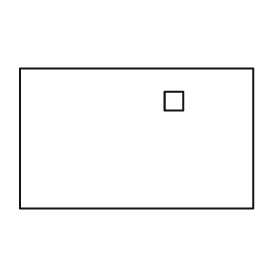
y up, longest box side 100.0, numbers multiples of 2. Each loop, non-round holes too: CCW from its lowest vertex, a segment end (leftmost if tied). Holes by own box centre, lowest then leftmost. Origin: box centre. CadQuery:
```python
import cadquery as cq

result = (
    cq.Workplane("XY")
    .moveTo(-50.0, -30.0)
    .lineTo(50.0, -30.0)
    .lineTo(50.0, 30.0)
    .lineTo(-50.0, 30.0)
    .close()
    .moveTo(12.0, 12.0)
    .lineTo(20.0, 12.0)
    .lineTo(20.0, 20.0)
    .lineTo(12.0, 20.0)
    .close()
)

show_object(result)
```